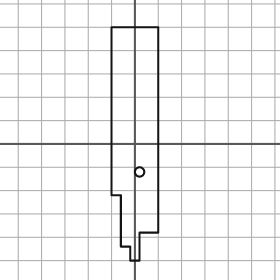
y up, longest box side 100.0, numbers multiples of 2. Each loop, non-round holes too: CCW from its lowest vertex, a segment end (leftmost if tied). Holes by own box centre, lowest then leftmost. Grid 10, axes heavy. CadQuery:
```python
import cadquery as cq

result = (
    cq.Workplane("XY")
    .moveTo(-2.0, -50.0)
    .lineTo(2.0, -50.0)
    .lineTo(2.0, -38.0)
    .lineTo(10.0, -38.0)
    .lineTo(10.0, 50.0)
    .lineTo(-10.0, 50.0)
    .lineTo(-10.0, -22.0)
    .lineTo(-6.0, -22.0)
    .lineTo(-6.0, -44.0)
    .lineTo(-2.0, -44.0)
    .close()
    .moveTo(2.0, -12.0)
    .circle(2.0)
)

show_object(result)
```